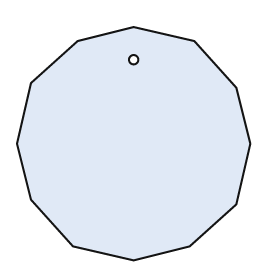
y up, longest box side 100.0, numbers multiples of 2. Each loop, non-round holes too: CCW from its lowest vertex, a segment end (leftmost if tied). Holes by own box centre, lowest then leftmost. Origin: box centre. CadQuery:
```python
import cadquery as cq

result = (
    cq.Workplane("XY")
    .moveTo(0.0, -50.0)
    .lineTo(24.0, -44.0)
    .lineTo(44.0, -26.0)
    .lineTo(50.0, 0.0)
    .lineTo(44.0, 24.0)
    .lineTo(26.0, 44.0)
    .lineTo(0.0, 50.0)
    .lineTo(-24.0, 44.0)
    .lineTo(-44.0, 26.0)
    .lineTo(-50.0, 0.0)
    .lineTo(-44.0, -24.0)
    .lineTo(-26.0, -44.0)
    .close()
    .moveTo(0.0, 36.0)
    .circle(2.0)
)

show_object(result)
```